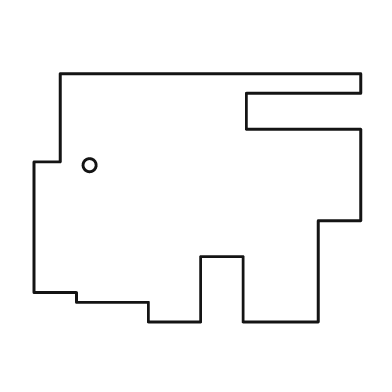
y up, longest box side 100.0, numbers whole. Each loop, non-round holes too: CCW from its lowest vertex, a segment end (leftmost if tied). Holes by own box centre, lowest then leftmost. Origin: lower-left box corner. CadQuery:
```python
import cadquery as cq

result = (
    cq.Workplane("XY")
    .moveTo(35.0, 0.0)
    .lineTo(51.0, 0.0)
    .lineTo(51.0, 20.0)
    .lineTo(64.0, 20.0)
    .lineTo(64.0, 0.0)
    .lineTo(87.0, 0.0)
    .lineTo(87.0, 31.0)
    .lineTo(100.0, 31.0)
    .lineTo(100.0, 59.0)
    .lineTo(65.0, 59.0)
    .lineTo(65.0, 70.0)
    .lineTo(100.0, 70.0)
    .lineTo(100.0, 76.0)
    .lineTo(8.0, 76.0)
    .lineTo(8.0, 49.0)
    .lineTo(0.0, 49.0)
    .lineTo(0.0, 9.0)
    .lineTo(13.0, 9.0)
    .lineTo(13.0, 6.0)
    .lineTo(35.0, 6.0)
    .close()
    .moveTo(17.0, 48.0)
    .circle(2.0)
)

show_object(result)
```